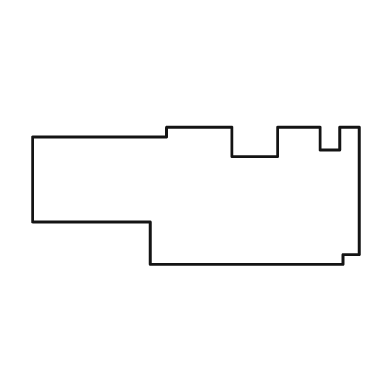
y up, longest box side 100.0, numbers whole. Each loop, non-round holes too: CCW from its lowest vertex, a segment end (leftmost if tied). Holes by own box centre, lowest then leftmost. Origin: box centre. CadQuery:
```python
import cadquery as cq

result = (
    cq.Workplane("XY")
    .moveTo(-14.0, -21.0)
    .lineTo(45.0, -21.0)
    .lineTo(45.0, -18.0)
    .lineTo(50.0, -18.0)
    .lineTo(50.0, 21.0)
    .lineTo(44.0, 21.0)
    .lineTo(44.0, 14.0)
    .lineTo(38.0, 14.0)
    .lineTo(38.0, 21.0)
    .lineTo(25.0, 21.0)
    .lineTo(25.0, 12.0)
    .lineTo(11.0, 12.0)
    .lineTo(11.0, 21.0)
    .lineTo(-9.0, 21.0)
    .lineTo(-9.0, 18.0)
    .lineTo(-50.0, 18.0)
    .lineTo(-50.0, -8.0)
    .lineTo(-14.0, -8.0)
    .close()
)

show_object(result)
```